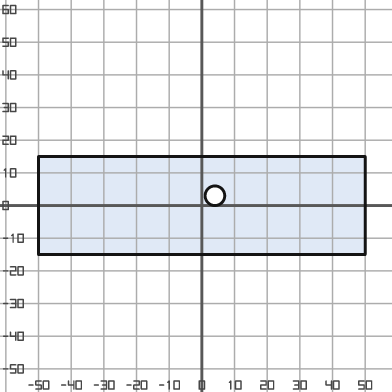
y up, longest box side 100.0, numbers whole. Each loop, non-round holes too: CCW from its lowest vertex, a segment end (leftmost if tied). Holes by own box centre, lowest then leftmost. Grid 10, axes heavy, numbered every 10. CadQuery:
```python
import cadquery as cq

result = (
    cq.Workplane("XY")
    .moveTo(-50.0, -15.0)
    .lineTo(50.0, -15.0)
    .lineTo(50.0, 15.0)
    .lineTo(-50.0, 15.0)
    .close()
    .moveTo(4.0, 3.0)
    .circle(3.0)
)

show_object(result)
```